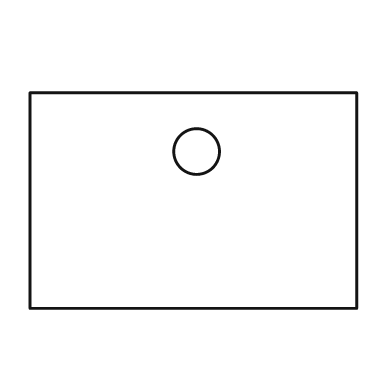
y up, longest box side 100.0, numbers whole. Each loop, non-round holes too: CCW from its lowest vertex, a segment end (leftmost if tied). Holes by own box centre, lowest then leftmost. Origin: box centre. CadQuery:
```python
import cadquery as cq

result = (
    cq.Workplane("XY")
    .moveTo(-50.0, -33.0)
    .lineTo(50.0, -33.0)
    .lineTo(50.0, 33.0)
    .lineTo(-50.0, 33.0)
    .close()
    .moveTo(1.0, 15.0)
    .circle(7.0)
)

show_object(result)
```